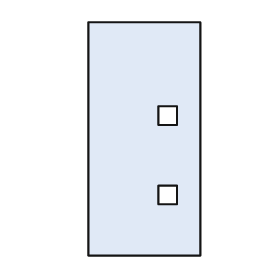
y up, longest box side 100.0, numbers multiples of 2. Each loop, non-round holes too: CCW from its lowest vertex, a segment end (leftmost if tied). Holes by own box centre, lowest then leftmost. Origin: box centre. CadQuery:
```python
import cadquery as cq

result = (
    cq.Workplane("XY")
    .moveTo(-24.0, -50.0)
    .lineTo(24.0, -50.0)
    .lineTo(24.0, 50.0)
    .lineTo(-24.0, 50.0)
    .close()
    .moveTo(6.0, -28.0)
    .lineTo(14.0, -28.0)
    .lineTo(14.0, -20.0)
    .lineTo(6.0, -20.0)
    .close()
    .moveTo(6.0, 6.0)
    .lineTo(14.0, 6.0)
    .lineTo(14.0, 14.0)
    .lineTo(6.0, 14.0)
    .close()
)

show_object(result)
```